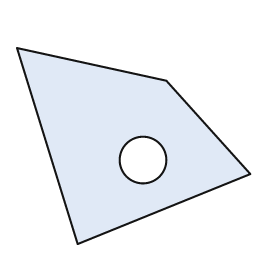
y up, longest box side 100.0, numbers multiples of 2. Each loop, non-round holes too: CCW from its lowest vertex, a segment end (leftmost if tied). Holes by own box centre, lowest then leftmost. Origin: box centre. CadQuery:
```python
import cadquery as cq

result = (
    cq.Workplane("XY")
    .moveTo(-24.0, -42.0)
    .lineTo(50.0, -12.0)
    .lineTo(14.0, 28.0)
    .lineTo(-50.0, 42.0)
    .close()
    .moveTo(4.0, -6.0)
    .circle(10.0)
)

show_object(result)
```